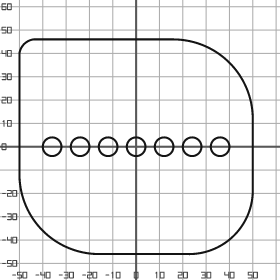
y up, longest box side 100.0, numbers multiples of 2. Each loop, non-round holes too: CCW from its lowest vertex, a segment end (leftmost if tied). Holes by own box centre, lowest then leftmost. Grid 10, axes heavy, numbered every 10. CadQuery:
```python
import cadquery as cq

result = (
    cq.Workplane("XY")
    .moveTo(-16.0, -46.0)
    .lineTo(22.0, -46.0)
    .threePointArc((42.0, -38.0), (50.0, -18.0))
    .lineTo(50.0, 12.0)
    .threePointArc((40.0, 36.0), (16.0, 46.0))
    .lineTo(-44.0, 46.0)
    .threePointArc((-48.0, 44.0), (-50.0, 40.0))
    .lineTo(-50.0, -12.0)
    .threePointArc((-40.0, -36.0), (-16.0, -46.0))
    .close()
    .moveTo(-36.0, 0.0)
    .circle(4.0)
    .moveTo(-24.0, 0.0)
    .circle(4.0)
    .moveTo(-12.0, 0.0)
    .circle(4.0)
    .moveTo(0.0, 0.0)
    .circle(4.0)
    .moveTo(12.0, 0.0)
    .circle(4.0)
    .moveTo(24.0, 0.0)
    .circle(4.0)
    .moveTo(36.0, 0.0)
    .circle(4.0)
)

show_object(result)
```